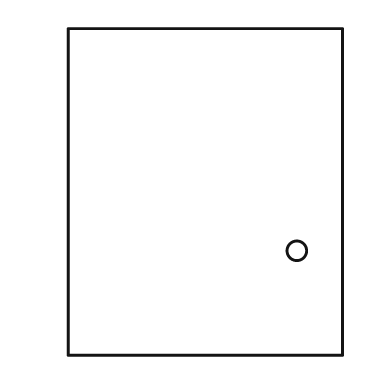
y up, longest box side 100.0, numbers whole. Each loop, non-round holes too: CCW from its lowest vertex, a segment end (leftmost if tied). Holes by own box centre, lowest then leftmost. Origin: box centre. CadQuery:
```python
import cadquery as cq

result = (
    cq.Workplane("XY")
    .moveTo(-42.0, -50.0)
    .lineTo(42.0, -50.0)
    .lineTo(42.0, 50.0)
    .lineTo(-42.0, 50.0)
    .close()
    .moveTo(28.0, -18.0)
    .circle(3.0)
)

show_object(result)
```